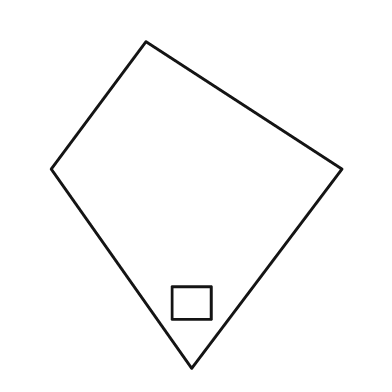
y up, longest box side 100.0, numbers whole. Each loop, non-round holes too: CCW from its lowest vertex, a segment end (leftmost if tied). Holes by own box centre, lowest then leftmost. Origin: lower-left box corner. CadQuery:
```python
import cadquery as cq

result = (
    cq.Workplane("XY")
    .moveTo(43.0, 0.0)
    .lineTo(89.0, 61.0)
    .lineTo(29.0, 100.0)
    .lineTo(0.0, 61.0)
    .close()
    .moveTo(37.0, 15.0)
    .lineTo(49.0, 15.0)
    .lineTo(49.0, 25.0)
    .lineTo(37.0, 25.0)
    .close()
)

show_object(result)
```